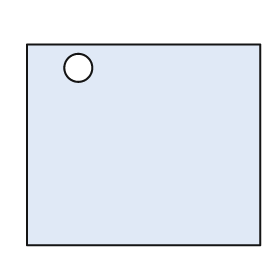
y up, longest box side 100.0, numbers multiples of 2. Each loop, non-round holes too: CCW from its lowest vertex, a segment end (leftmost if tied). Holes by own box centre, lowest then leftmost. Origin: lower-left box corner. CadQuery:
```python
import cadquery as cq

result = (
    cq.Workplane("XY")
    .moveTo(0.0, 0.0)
    .lineTo(100.0, 0.0)
    .lineTo(100.0, 86.0)
    .lineTo(0.0, 86.0)
    .close()
    .moveTo(22.0, 76.0)
    .circle(6.0)
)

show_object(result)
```